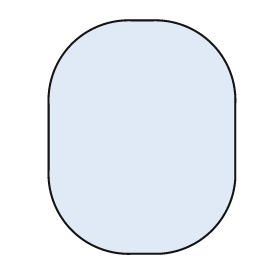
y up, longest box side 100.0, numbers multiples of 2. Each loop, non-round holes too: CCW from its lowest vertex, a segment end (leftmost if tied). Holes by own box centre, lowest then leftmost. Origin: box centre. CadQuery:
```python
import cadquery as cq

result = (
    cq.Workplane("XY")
    .moveTo(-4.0, -50.0)
    .lineTo(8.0, -50.0)
    .threePointArc((30.0, -40.0), (40.0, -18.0))
    .lineTo(40.0, 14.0)
    .threePointArc((30.0, 40.0), (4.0, 50.0))
    .lineTo(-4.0, 50.0)
    .threePointArc((-30.0, 40.0), (-40.0, 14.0))
    .lineTo(-40.0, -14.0)
    .threePointArc((-30.0, -40.0), (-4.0, -50.0))
    .close()
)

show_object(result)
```